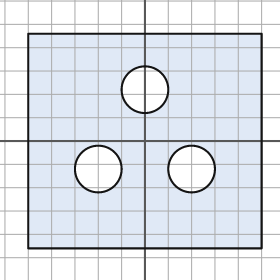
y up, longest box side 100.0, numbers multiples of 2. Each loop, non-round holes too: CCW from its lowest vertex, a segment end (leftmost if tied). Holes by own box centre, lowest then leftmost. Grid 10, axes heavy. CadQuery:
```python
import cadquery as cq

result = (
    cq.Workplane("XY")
    .moveTo(-50.0, -46.0)
    .lineTo(50.0, -46.0)
    .lineTo(50.0, 46.0)
    .lineTo(-50.0, 46.0)
    .close()
    .moveTo(-20.0, -12.0)
    .circle(10.0)
    .moveTo(20.0, -12.0)
    .circle(10.0)
    .moveTo(0.0, 22.0)
    .circle(10.0)
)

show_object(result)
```